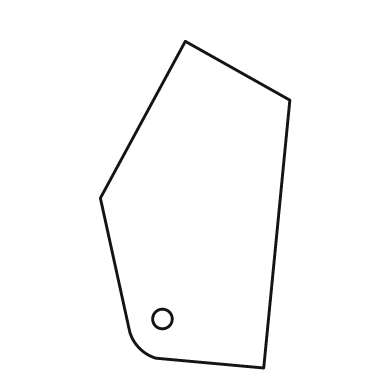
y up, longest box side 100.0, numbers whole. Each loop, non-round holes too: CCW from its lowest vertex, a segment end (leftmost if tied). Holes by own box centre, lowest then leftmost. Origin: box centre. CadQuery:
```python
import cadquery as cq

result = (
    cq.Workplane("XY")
    .moveTo(21.0, -50.0)
    .lineTo(29.0, 32.0)
    .lineTo(-3.0, 50.0)
    .lineTo(-29.0, 2.0)
    .lineTo(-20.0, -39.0)
    .threePointArc((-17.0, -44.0), (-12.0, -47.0))
    .close()
    .moveTo(-10.0, -35.0)
    .circle(3.0)
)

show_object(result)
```